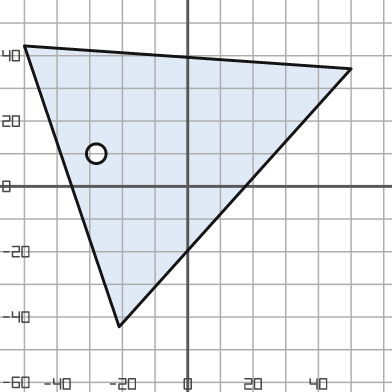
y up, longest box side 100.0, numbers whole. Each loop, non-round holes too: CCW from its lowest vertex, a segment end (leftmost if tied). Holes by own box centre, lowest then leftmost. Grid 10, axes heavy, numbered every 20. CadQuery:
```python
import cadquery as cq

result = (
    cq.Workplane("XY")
    .moveTo(-21.0, -43.0)
    .lineTo(50.0, 36.0)
    .lineTo(-50.0, 43.0)
    .close()
    .moveTo(-28.0, 10.0)
    .circle(3.0)
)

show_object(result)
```